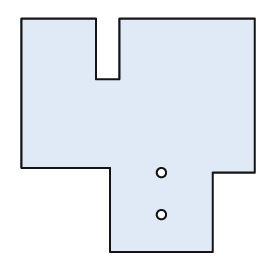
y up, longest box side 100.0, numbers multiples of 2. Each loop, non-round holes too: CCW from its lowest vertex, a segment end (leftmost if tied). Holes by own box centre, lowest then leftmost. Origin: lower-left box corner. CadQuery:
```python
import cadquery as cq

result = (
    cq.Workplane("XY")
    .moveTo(38.0, 0.0)
    .lineTo(82.0, 0.0)
    .lineTo(82.0, 34.0)
    .lineTo(100.0, 34.0)
    .lineTo(100.0, 100.0)
    .lineTo(42.0, 100.0)
    .lineTo(42.0, 74.0)
    .lineTo(32.0, 74.0)
    .lineTo(32.0, 100.0)
    .lineTo(0.0, 100.0)
    .lineTo(0.0, 36.0)
    .lineTo(38.0, 36.0)
    .close()
    .moveTo(60.0, 16.0)
    .circle(2.0)
    .moveTo(60.0, 34.0)
    .circle(2.0)
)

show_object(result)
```